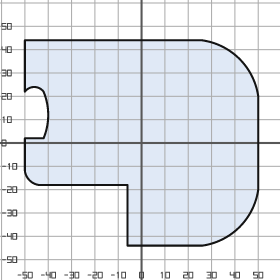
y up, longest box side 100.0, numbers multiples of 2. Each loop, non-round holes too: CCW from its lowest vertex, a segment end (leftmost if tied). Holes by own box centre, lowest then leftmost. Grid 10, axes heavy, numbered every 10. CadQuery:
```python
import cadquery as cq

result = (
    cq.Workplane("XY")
    .moveTo(-6.0, -44.0)
    .lineTo(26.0, -44.0)
    .threePointArc((42.0, -36.0), (50.0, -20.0))
    .lineTo(50.0, 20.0)
    .threePointArc((42.0, 36.0), (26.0, 44.0))
    .lineTo(-50.0, 44.0)
    .lineTo(-50.0, 22.0)
    .threePointArc((-46.0, 24.0), (-42.0, 22.0))
    .threePointArc((-40.0, 12.0), (-42.0, 2.0))
    .lineTo(-50.0, 2.0)
    .lineTo(-50.0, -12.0)
    .threePointArc((-48.0, -16.0), (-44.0, -18.0))
    .lineTo(-6.0, -18.0)
    .close()
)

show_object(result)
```